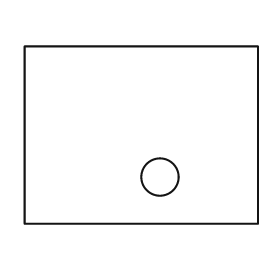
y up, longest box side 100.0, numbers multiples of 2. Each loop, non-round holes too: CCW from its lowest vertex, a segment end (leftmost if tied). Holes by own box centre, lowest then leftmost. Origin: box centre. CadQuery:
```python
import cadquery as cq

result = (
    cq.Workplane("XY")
    .moveTo(-50.0, -38.0)
    .lineTo(50.0, -38.0)
    .lineTo(50.0, 38.0)
    .lineTo(-50.0, 38.0)
    .close()
    .moveTo(8.0, -18.0)
    .circle(8.0)
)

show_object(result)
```